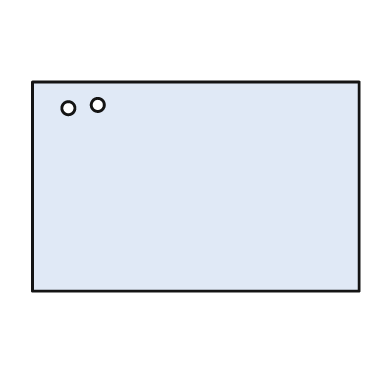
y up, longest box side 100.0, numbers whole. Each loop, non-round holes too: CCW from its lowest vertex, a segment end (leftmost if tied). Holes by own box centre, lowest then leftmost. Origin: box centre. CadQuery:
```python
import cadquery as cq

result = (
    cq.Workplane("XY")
    .moveTo(-50.0, -32.0)
    .lineTo(50.0, -32.0)
    .lineTo(50.0, 32.0)
    .lineTo(-50.0, 32.0)
    .close()
    .moveTo(-39.0, 24.0)
    .circle(2.0)
    .moveTo(-30.0, 25.0)
    .circle(2.0)
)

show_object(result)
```